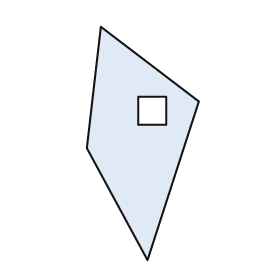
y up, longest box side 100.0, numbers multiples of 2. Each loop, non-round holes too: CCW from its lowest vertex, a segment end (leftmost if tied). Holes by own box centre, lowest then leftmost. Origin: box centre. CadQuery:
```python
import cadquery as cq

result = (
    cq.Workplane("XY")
    .moveTo(2.0, -50.0)
    .lineTo(24.0, 18.0)
    .lineTo(-18.0, 50.0)
    .lineTo(-24.0, -2.0)
    .close()
    .moveTo(-2.0, 8.0)
    .lineTo(10.0, 8.0)
    .lineTo(10.0, 20.0)
    .lineTo(-2.0, 20.0)
    .close()
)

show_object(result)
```